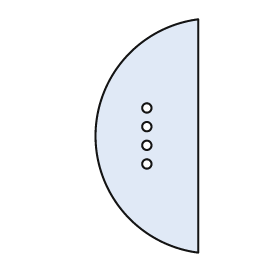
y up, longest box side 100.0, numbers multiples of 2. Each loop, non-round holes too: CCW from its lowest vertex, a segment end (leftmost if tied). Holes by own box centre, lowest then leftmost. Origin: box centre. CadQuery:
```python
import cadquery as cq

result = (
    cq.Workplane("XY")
    .moveTo(22.0, -50.0)
    .lineTo(22.0, 50.0)
    .threePointArc((-22.0, 0.0), (22.0, -50.0))
    .close()
    .moveTo(0.0, -12.0)
    .circle(2.0)
    .moveTo(0.0, -4.0)
    .circle(2.0)
    .moveTo(0.0, 4.0)
    .circle(2.0)
    .moveTo(0.0, 12.0)
    .circle(2.0)
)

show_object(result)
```